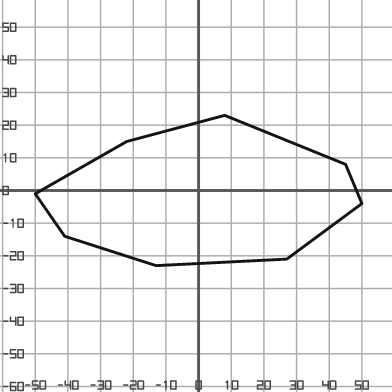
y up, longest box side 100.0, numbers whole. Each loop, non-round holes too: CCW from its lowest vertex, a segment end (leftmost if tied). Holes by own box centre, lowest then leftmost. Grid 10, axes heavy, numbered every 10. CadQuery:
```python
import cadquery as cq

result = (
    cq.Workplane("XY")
    .moveTo(-13.0, -23.0)
    .lineTo(27.0, -21.0)
    .lineTo(50.0, -4.0)
    .lineTo(45.0, 8.0)
    .lineTo(8.0, 23.0)
    .lineTo(-22.0, 15.0)
    .lineTo(-50.0, -1.0)
    .lineTo(-41.0, -14.0)
    .close()
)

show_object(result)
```